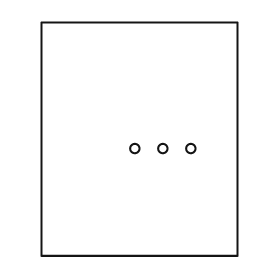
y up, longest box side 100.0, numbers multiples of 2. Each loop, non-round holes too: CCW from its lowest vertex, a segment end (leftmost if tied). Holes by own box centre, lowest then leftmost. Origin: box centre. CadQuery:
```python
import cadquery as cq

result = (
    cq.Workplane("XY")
    .moveTo(-42.0, -50.0)
    .lineTo(42.0, -50.0)
    .lineTo(42.0, 50.0)
    .lineTo(-42.0, 50.0)
    .close()
    .moveTo(-2.0, -4.0)
    .circle(2.0)
    .moveTo(10.0, -4.0)
    .circle(2.0)
    .moveTo(22.0, -4.0)
    .circle(2.0)
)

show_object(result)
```